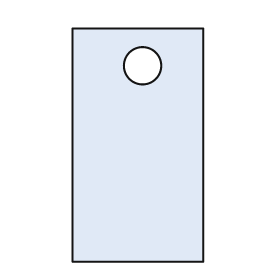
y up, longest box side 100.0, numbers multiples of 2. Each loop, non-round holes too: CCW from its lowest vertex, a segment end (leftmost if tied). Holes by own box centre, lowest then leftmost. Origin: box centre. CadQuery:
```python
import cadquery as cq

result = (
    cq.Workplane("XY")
    .moveTo(-28.0, -50.0)
    .lineTo(28.0, -50.0)
    .lineTo(28.0, 50.0)
    .lineTo(-28.0, 50.0)
    .close()
    .moveTo(2.0, 34.0)
    .circle(8.0)
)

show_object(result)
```